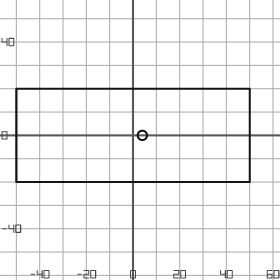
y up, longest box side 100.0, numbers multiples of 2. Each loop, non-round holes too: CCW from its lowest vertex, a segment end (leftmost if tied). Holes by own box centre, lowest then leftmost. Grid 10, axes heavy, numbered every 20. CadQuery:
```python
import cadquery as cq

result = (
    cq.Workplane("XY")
    .moveTo(-50.0, -20.0)
    .lineTo(50.0, -20.0)
    .lineTo(50.0, 20.0)
    .lineTo(-50.0, 20.0)
    .close()
    .moveTo(4.0, 0.0)
    .circle(2.0)
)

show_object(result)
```